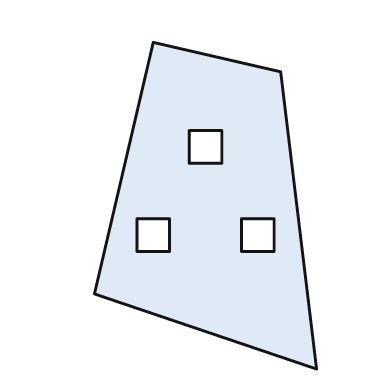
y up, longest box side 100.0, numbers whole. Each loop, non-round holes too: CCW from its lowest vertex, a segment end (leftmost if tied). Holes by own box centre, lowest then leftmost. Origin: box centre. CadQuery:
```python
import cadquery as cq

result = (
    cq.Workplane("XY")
    .moveTo(34.0, -50.0)
    .lineTo(23.0, 41.0)
    .lineTo(-16.0, 50.0)
    .lineTo(-34.0, -27.0)
    .close()
    .moveTo(-21.0, -14.0)
    .lineTo(-11.0, -14.0)
    .lineTo(-11.0, -4.0)
    .lineTo(-21.0, -4.0)
    .close()
    .moveTo(11.0, -14.0)
    .lineTo(21.0, -14.0)
    .lineTo(21.0, -4.0)
    .lineTo(11.0, -4.0)
    .close()
    .moveTo(-5.0, 13.0)
    .lineTo(5.0, 13.0)
    .lineTo(5.0, 23.0)
    .lineTo(-5.0, 23.0)
    .close()
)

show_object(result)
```